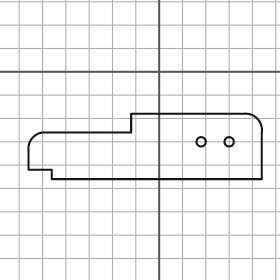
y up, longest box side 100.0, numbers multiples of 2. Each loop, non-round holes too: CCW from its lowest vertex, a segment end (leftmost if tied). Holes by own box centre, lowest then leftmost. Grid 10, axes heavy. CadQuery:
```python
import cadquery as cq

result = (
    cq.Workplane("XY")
    .moveTo(-46.0, -46.0)
    .lineTo(44.0, -46.0)
    .lineTo(44.0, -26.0)
    .threePointArc((42.0, -20.0), (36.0, -18.0))
    .lineTo(-12.0, -18.0)
    .lineTo(-12.0, -26.0)
    .lineTo(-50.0, -26.0)
    .threePointArc((-54.0, -28.0), (-56.0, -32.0))
    .lineTo(-56.0, -42.0)
    .lineTo(-46.0, -42.0)
    .close()
    .moveTo(18.0, -30.0)
    .circle(2.0)
    .moveTo(30.0, -30.0)
    .circle(2.0)
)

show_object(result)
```